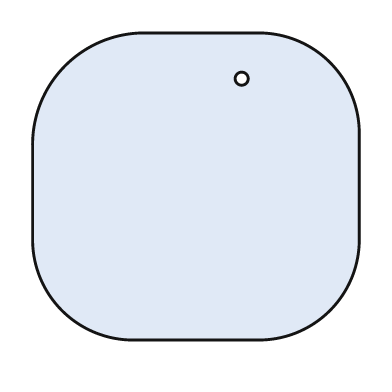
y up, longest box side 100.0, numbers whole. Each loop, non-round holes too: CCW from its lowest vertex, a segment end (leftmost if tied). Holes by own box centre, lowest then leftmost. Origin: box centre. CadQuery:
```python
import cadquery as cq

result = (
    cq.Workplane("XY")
    .moveTo(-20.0, -47.0)
    .lineTo(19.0, -47.0)
    .threePointArc((41.0, -38.0), (50.0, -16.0))
    .lineTo(50.0, 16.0)
    .threePointArc((41.0, 38.0), (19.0, 47.0))
    .lineTo(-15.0, 47.0)
    .threePointArc((-40.0, 37.0), (-50.0, 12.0))
    .lineTo(-50.0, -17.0)
    .threePointArc((-41.0, -38.0), (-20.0, -47.0))
    .close()
    .moveTo(14.0, 33.0)
    .circle(2.0)
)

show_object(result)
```